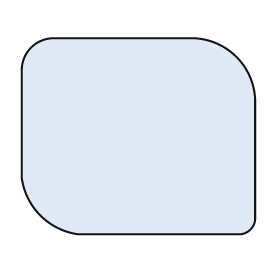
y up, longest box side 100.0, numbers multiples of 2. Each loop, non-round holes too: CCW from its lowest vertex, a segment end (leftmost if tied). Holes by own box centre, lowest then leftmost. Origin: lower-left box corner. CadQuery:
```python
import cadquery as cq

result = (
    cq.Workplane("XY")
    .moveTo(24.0, 0.0)
    .lineTo(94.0, 0.0)
    .threePointArc((98.0, 2.0), (100.0, 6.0))
    .lineTo(100.0, 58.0)
    .threePointArc((92.0, 76.0), (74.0, 84.0))
    .lineTo(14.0, 84.0)
    .threePointArc((4.0, 80.0), (0.0, 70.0))
    .lineTo(0.0, 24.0)
    .threePointArc((8.0, 8.0), (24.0, 0.0))
    .close()
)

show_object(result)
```